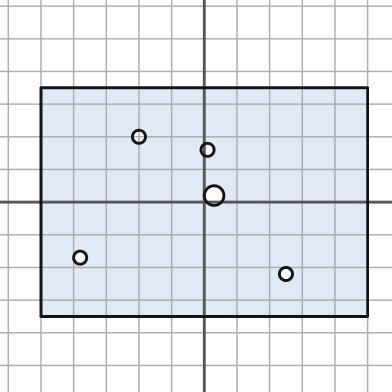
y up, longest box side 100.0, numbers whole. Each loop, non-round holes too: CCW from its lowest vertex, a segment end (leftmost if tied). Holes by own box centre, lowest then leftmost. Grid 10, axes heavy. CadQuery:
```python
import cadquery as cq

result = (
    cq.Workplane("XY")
    .moveTo(-50.0, -35.0)
    .lineTo(50.0, -35.0)
    .lineTo(50.0, 35.0)
    .lineTo(-50.0, 35.0)
    .close()
    .moveTo(25.0, -22.0)
    .circle(2.0)
    .moveTo(-38.0, -17.0)
    .circle(2.0)
    .moveTo(3.0, 2.0)
    .circle(3.0)
    .moveTo(1.0, 16.0)
    .circle(2.0)
    .moveTo(-20.0, 20.0)
    .circle(2.0)
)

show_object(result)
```